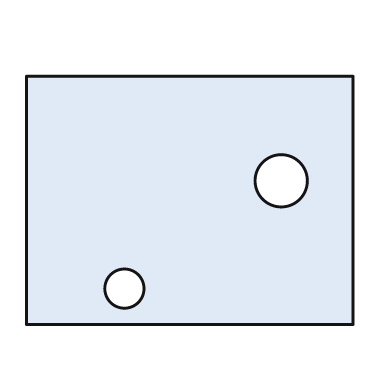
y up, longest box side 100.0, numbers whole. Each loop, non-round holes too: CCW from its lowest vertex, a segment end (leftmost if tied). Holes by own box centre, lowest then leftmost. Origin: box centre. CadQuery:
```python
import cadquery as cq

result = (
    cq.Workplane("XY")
    .moveTo(-50.0, -38.0)
    .lineTo(50.0, -38.0)
    .lineTo(50.0, 38.0)
    .lineTo(-50.0, 38.0)
    .close()
    .moveTo(-20.0, -27.0)
    .circle(6.0)
    .moveTo(28.0, 6.0)
    .circle(8.0)
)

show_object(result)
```